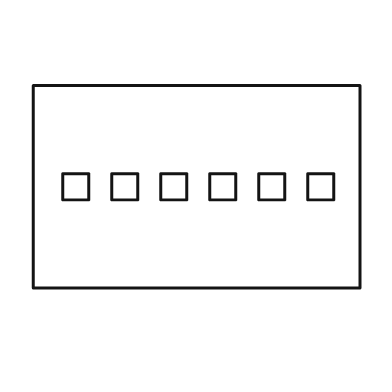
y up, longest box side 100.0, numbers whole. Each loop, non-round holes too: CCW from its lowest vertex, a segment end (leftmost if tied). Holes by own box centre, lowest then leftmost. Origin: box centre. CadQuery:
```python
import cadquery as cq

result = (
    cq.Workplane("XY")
    .moveTo(-50.0, -31.0)
    .lineTo(50.0, -31.0)
    .lineTo(50.0, 31.0)
    .lineTo(-50.0, 31.0)
    .close()
    .moveTo(-41.0, -4.0)
    .lineTo(-33.0, -4.0)
    .lineTo(-33.0, 4.0)
    .lineTo(-41.0, 4.0)
    .close()
    .moveTo(-26.0, -4.0)
    .lineTo(-18.0, -4.0)
    .lineTo(-18.0, 4.0)
    .lineTo(-26.0, 4.0)
    .close()
    .moveTo(-11.0, -4.0)
    .lineTo(-3.0, -4.0)
    .lineTo(-3.0, 4.0)
    .lineTo(-11.0, 4.0)
    .close()
    .moveTo(4.0, -4.0)
    .lineTo(12.0, -4.0)
    .lineTo(12.0, 4.0)
    .lineTo(4.0, 4.0)
    .close()
    .moveTo(19.0, -4.0)
    .lineTo(27.0, -4.0)
    .lineTo(27.0, 4.0)
    .lineTo(19.0, 4.0)
    .close()
    .moveTo(34.0, -4.0)
    .lineTo(42.0, -4.0)
    .lineTo(42.0, 4.0)
    .lineTo(34.0, 4.0)
    .close()
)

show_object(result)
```